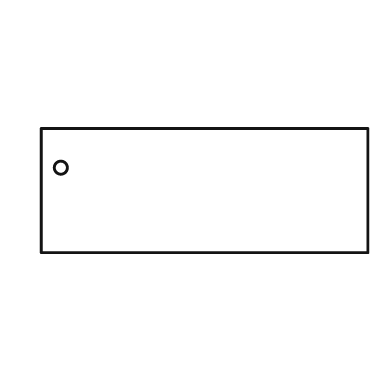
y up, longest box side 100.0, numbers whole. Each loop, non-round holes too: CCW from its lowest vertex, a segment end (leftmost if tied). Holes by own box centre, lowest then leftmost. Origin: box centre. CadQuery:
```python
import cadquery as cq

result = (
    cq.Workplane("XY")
    .moveTo(-50.0, -19.0)
    .lineTo(50.0, -19.0)
    .lineTo(50.0, 19.0)
    .lineTo(-50.0, 19.0)
    .close()
    .moveTo(-44.0, 7.0)
    .circle(2.0)
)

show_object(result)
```